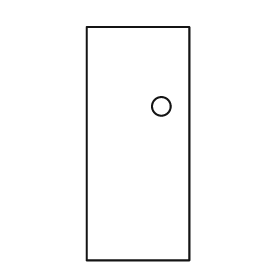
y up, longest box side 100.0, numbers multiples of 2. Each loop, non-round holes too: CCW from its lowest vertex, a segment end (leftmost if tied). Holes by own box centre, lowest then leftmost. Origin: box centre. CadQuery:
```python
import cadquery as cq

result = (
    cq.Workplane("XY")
    .moveTo(-22.0, -50.0)
    .lineTo(22.0, -50.0)
    .lineTo(22.0, 50.0)
    .lineTo(-22.0, 50.0)
    .close()
    .moveTo(10.0, 16.0)
    .circle(4.0)
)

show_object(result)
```